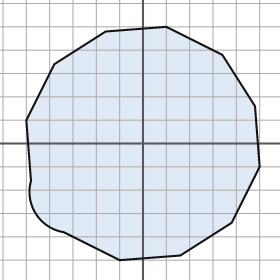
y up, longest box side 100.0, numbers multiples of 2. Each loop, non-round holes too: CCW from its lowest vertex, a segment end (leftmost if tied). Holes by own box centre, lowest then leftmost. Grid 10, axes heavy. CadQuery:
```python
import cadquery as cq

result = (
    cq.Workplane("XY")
    .moveTo(-10.0, -50.0)
    .lineTo(16.0, -48.0)
    .lineTo(38.0, -34.0)
    .lineTo(50.0, -10.0)
    .lineTo(48.0, 16.0)
    .lineTo(34.0, 38.0)
    .lineTo(10.0, 50.0)
    .lineTo(-16.0, 48.0)
    .lineTo(-38.0, 34.0)
    .lineTo(-50.0, 10.0)
    .lineTo(-48.0, -16.0)
    .threePointArc((-46.0, -30.0), (-34.0, -38.0))
    .close()
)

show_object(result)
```